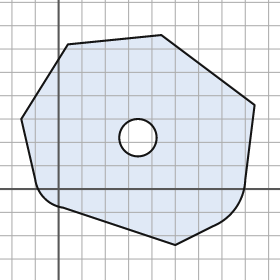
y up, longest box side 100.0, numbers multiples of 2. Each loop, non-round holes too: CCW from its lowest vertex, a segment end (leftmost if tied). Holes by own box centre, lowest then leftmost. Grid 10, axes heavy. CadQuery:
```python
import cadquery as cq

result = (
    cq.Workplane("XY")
    .moveTo(50.0, -24.0)
    .lineTo(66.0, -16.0)
    .threePointArc((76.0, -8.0), (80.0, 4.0))
    .lineTo(84.0, 36.0)
    .lineTo(44.0, 66.0)
    .lineTo(4.0, 62.0)
    .lineTo(-16.0, 30.0)
    .lineTo(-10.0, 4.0)
    .threePointArc((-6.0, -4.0), (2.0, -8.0))
    .close()
    .moveTo(34.0, 22.0)
    .circle(8.0)
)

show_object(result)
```